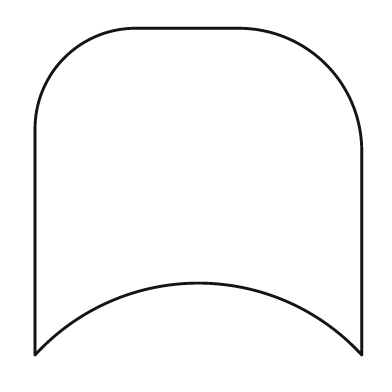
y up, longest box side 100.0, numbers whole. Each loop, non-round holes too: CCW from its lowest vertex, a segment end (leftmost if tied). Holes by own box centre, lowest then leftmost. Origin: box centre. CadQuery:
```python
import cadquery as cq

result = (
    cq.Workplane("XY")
    .moveTo(-50.0, -50.0)
    .threePointArc((0.0, -28.0), (50.0, -50.0))
    .lineTo(50.0, 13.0)
    .threePointArc((39.0, 39.0), (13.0, 50.0))
    .lineTo(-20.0, 50.0)
    .threePointArc((-41.0, 41.0), (-50.0, 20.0))
    .close()
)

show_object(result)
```